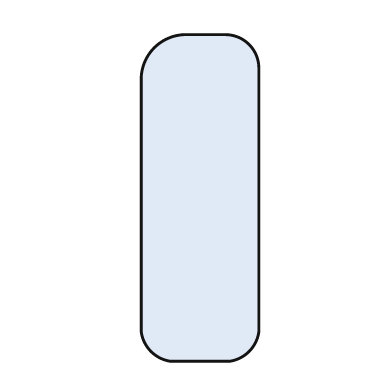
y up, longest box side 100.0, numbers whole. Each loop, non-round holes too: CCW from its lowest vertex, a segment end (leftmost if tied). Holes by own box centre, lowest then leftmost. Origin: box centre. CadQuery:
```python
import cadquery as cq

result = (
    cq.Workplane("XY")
    .moveTo(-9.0, -50.0)
    .lineTo(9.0, -50.0)
    .threePointArc((15.0, -47.0), (18.0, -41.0))
    .lineTo(18.0, 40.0)
    .threePointArc((15.0, 47.0), (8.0, 50.0))
    .lineTo(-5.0, 50.0)
    .threePointArc((-14.0, 46.0), (-18.0, 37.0))
    .lineTo(-18.0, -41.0)
    .threePointArc((-15.0, -47.0), (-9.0, -50.0))
    .close()
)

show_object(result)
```